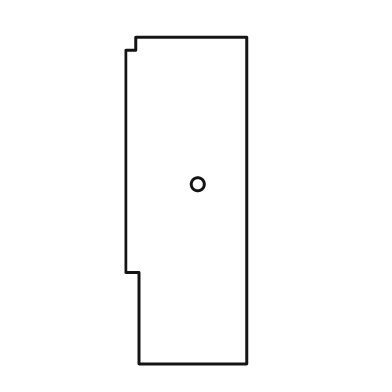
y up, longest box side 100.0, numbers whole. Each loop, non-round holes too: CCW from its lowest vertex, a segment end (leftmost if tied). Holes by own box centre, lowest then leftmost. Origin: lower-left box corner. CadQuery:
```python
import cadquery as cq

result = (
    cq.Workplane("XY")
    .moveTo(4.0, 0.0)
    .lineTo(37.0, 0.0)
    .lineTo(37.0, 100.0)
    .lineTo(3.0, 100.0)
    .lineTo(3.0, 96.0)
    .lineTo(0.0, 96.0)
    .lineTo(0.0, 28.0)
    .lineTo(4.0, 28.0)
    .close()
    .moveTo(22.0, 55.0)
    .circle(2.0)
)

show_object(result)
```